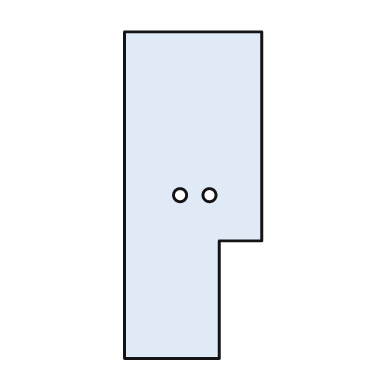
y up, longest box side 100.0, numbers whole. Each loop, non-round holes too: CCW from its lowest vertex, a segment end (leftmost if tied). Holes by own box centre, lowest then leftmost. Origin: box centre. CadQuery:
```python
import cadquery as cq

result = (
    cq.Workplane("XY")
    .moveTo(-21.0, -50.0)
    .lineTo(8.0, -50.0)
    .lineTo(8.0, -14.0)
    .lineTo(21.0, -14.0)
    .lineTo(21.0, 50.0)
    .lineTo(-21.0, 50.0)
    .close()
    .moveTo(-4.0, 0.0)
    .circle(2.0)
    .moveTo(5.0, 0.0)
    .circle(2.0)
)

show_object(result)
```